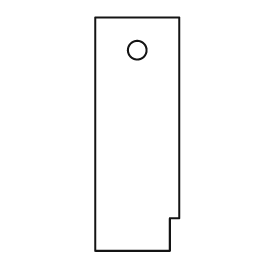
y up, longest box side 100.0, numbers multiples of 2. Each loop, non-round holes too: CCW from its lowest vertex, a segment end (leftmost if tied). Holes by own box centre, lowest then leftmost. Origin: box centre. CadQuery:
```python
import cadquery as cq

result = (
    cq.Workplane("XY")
    .moveTo(-18.0, -50.0)
    .lineTo(14.0, -50.0)
    .lineTo(14.0, -36.0)
    .lineTo(18.0, -36.0)
    .lineTo(18.0, 50.0)
    .lineTo(-18.0, 50.0)
    .close()
    .moveTo(0.0, 36.0)
    .circle(4.0)
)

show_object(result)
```